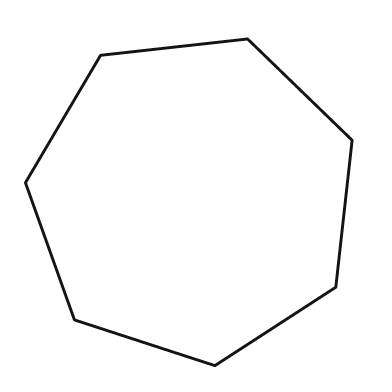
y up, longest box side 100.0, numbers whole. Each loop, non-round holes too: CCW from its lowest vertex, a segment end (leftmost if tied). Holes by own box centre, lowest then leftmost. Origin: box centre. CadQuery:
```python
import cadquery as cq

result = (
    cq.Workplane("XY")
    .moveTo(8.0, -50.0)
    .lineTo(45.0, -26.0)
    .lineTo(50.0, 19.0)
    .lineTo(18.0, 50.0)
    .lineTo(-27.0, 45.0)
    .lineTo(-50.0, 6.0)
    .lineTo(-35.0, -36.0)
    .close()
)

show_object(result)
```